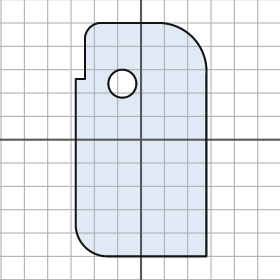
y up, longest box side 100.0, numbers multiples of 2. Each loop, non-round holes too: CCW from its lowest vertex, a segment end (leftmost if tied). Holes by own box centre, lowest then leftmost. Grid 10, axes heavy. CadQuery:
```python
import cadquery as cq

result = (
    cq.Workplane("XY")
    .moveTo(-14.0, -50.0)
    .lineTo(28.0, -50.0)
    .lineTo(28.0, 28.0)
    .threePointArc((22.0, 44.0), (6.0, 50.0))
    .lineTo(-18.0, 50.0)
    .threePointArc((-22.0, 48.0), (-24.0, 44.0))
    .lineTo(-24.0, 26.0)
    .lineTo(-28.0, 26.0)
    .lineTo(-28.0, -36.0)
    .threePointArc((-24.0, -46.0), (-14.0, -50.0))
    .close()
    .moveTo(-8.0, 24.0)
    .circle(6.0)
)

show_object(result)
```